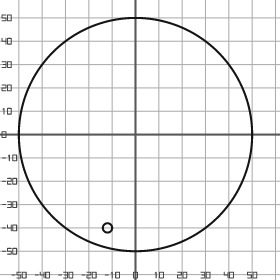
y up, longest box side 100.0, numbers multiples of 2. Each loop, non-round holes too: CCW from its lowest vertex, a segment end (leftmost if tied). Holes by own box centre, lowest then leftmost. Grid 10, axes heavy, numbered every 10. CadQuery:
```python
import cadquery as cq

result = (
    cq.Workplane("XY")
    .moveTo(0.0, 0.0)
    .circle(50.0)
    .moveTo(-12.0, -40.0)
    .circle(2.0)
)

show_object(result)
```